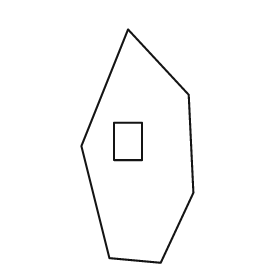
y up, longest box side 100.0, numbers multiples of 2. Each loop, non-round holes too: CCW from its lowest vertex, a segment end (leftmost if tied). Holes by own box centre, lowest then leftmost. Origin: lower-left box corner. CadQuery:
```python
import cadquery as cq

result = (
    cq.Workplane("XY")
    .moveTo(34.0, 0.0)
    .lineTo(48.0, 30.0)
    .lineTo(46.0, 72.0)
    .lineTo(20.0, 100.0)
    .lineTo(0.0, 50.0)
    .lineTo(12.0, 2.0)
    .close()
    .moveTo(14.0, 44.0)
    .lineTo(26.0, 44.0)
    .lineTo(26.0, 60.0)
    .lineTo(14.0, 60.0)
    .close()
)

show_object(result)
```